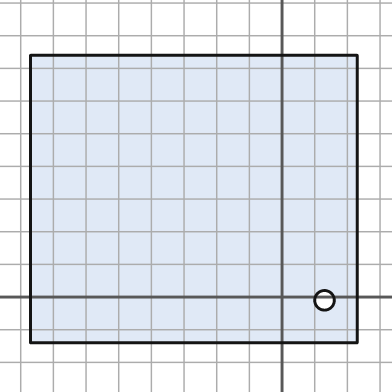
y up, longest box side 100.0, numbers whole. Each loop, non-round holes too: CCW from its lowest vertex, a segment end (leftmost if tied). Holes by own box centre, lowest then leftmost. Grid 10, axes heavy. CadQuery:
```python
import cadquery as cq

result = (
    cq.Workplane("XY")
    .moveTo(-77.0, -14.0)
    .lineTo(23.0, -14.0)
    .lineTo(23.0, 74.0)
    .lineTo(-77.0, 74.0)
    .close()
    .moveTo(13.0, -1.0)
    .circle(3.0)
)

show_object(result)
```